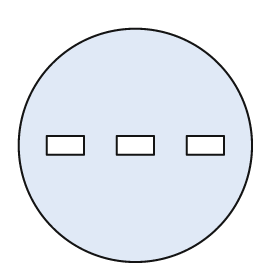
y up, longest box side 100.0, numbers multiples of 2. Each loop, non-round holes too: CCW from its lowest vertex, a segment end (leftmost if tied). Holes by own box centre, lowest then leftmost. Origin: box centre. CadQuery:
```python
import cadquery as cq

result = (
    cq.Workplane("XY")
    .moveTo(0.0, 0.0)
    .circle(50.0)
    .moveTo(-38.0, -4.0)
    .lineTo(-22.0, -4.0)
    .lineTo(-22.0, 4.0)
    .lineTo(-38.0, 4.0)
    .close()
    .moveTo(-8.0, -4.0)
    .lineTo(8.0, -4.0)
    .lineTo(8.0, 4.0)
    .lineTo(-8.0, 4.0)
    .close()
    .moveTo(22.0, -4.0)
    .lineTo(38.0, -4.0)
    .lineTo(38.0, 4.0)
    .lineTo(22.0, 4.0)
    .close()
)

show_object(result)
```